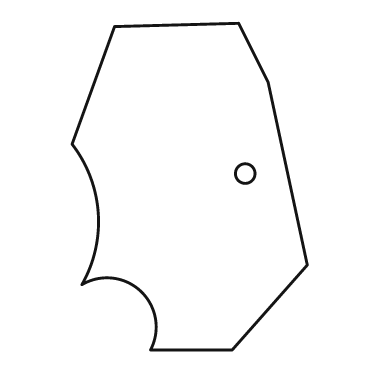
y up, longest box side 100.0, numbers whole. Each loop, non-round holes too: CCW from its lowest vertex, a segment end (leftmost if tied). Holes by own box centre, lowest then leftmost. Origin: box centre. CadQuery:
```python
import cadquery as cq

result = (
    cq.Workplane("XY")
    .moveTo(-12.0, -50.0)
    .lineTo(13.0, -50.0)
    .lineTo(36.0, -24.0)
    .lineTo(24.0, 32.0)
    .lineTo(15.0, 50.0)
    .lineTo(-23.0, 49.0)
    .lineTo(-36.0, 13.0)
    .threePointArc((-28.0, -8.0), (-33.0, -30.0))
    .threePointArc((-15.0, -32.0), (-12.0, -50.0))
    .close()
    .moveTo(17.0, 4.0)
    .circle(3.0)
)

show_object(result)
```